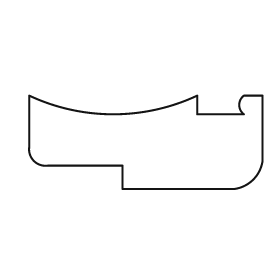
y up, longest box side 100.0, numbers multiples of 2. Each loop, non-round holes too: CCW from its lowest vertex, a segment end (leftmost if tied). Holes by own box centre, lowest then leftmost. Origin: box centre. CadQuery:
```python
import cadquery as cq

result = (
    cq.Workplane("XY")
    .moveTo(-10.0, -20.0)
    .lineTo(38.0, -20.0)
    .threePointArc((46.0, -16.0), (50.0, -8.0))
    .lineTo(50.0, 20.0)
    .lineTo(42.0, 20.0)
    .threePointArc((40.0, 16.0), (42.0, 12.0))
    .lineTo(22.0, 12.0)
    .lineTo(22.0, 20.0)
    .threePointArc((-14.0, 12.0), (-50.0, 20.0))
    .lineTo(-50.0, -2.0)
    .threePointArc((-48.0, -8.0), (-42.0, -10.0))
    .lineTo(-10.0, -10.0)
    .close()
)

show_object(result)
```